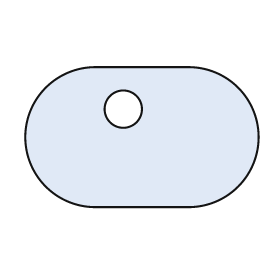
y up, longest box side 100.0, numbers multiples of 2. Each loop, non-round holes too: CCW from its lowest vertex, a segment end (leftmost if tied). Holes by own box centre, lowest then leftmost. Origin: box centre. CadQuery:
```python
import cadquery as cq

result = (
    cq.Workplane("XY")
    .moveTo(-20.0, -30.0)
    .lineTo(20.0, -30.0)
    .threePointArc((50.0, 0.0), (20.0, 30.0))
    .lineTo(-20.0, 30.0)
    .threePointArc((-50.0, 0.0), (-20.0, -30.0))
    .close()
    .moveTo(-8.0, 12.0)
    .circle(8.0)
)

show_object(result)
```